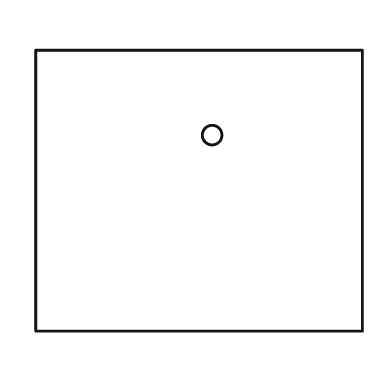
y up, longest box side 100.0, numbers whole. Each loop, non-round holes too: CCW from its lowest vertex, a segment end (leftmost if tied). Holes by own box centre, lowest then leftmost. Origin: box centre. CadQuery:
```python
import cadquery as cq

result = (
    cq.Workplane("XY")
    .moveTo(-50.0, -43.0)
    .lineTo(50.0, -43.0)
    .lineTo(50.0, 43.0)
    .lineTo(-50.0, 43.0)
    .close()
    .moveTo(4.0, 17.0)
    .circle(3.0)
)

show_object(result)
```